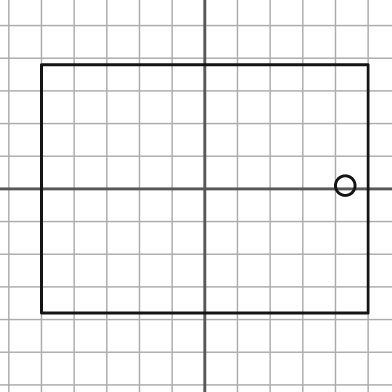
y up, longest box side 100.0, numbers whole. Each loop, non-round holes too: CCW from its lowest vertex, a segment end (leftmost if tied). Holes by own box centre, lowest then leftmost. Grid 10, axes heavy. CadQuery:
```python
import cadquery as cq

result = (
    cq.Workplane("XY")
    .moveTo(-50.0, -38.0)
    .lineTo(50.0, -38.0)
    .lineTo(50.0, 38.0)
    .lineTo(-50.0, 38.0)
    .close()
    .moveTo(43.0, 1.0)
    .circle(3.0)
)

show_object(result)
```